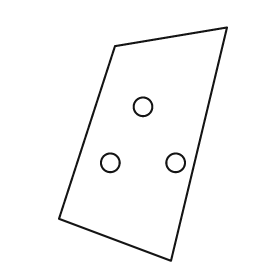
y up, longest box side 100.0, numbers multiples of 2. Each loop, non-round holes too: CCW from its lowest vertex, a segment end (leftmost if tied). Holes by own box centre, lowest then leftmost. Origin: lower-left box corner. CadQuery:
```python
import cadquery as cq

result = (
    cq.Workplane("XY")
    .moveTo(48.0, 0.0)
    .lineTo(72.0, 100.0)
    .lineTo(24.0, 92.0)
    .lineTo(0.0, 18.0)
    .close()
    .moveTo(22.0, 42.0)
    .circle(4.0)
    .moveTo(50.0, 42.0)
    .circle(4.0)
    .moveTo(36.0, 66.0)
    .circle(4.0)
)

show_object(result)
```